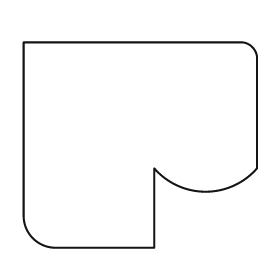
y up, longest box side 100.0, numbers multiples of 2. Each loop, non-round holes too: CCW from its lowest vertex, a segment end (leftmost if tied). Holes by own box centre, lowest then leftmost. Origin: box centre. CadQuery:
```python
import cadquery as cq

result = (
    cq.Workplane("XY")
    .moveTo(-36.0, -44.0)
    .lineTo(6.0, -44.0)
    .lineTo(6.0, -10.0)
    .threePointArc((28.0, -20.0), (50.0, -10.0))
    .lineTo(50.0, 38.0)
    .threePointArc((48.0, 42.0), (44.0, 44.0))
    .lineTo(-50.0, 44.0)
    .lineTo(-50.0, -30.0)
    .threePointArc((-46.0, -40.0), (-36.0, -44.0))
    .close()
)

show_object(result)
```